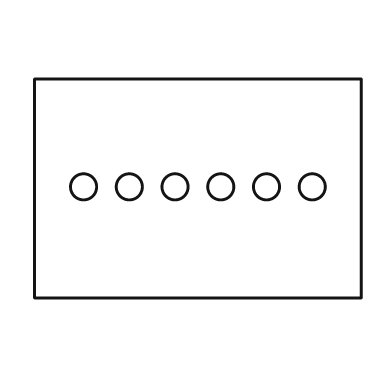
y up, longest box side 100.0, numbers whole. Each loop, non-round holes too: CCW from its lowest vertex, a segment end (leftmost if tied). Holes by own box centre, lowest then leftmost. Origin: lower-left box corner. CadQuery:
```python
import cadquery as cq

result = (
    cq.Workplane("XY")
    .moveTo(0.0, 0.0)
    .lineTo(100.0, 0.0)
    .lineTo(100.0, 67.0)
    .lineTo(0.0, 67.0)
    .close()
    .moveTo(15.0, 34.0)
    .circle(4.0)
    .moveTo(29.0, 34.0)
    .circle(4.0)
    .moveTo(43.0, 34.0)
    .circle(4.0)
    .moveTo(57.0, 34.0)
    .circle(4.0)
    .moveTo(71.0, 34.0)
    .circle(4.0)
    .moveTo(85.0, 34.0)
    .circle(4.0)
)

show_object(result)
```